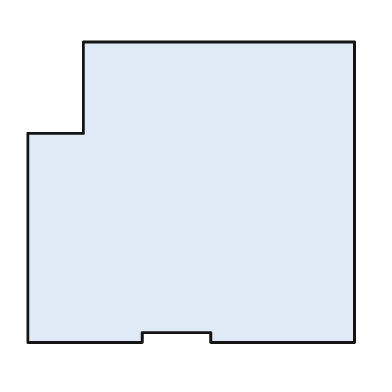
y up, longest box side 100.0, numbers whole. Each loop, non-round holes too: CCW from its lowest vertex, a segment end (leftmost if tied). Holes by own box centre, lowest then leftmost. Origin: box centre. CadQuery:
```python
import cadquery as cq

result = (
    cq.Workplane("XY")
    .moveTo(-50.0, -46.0)
    .lineTo(-15.0, -46.0)
    .lineTo(-15.0, -43.0)
    .lineTo(6.0, -43.0)
    .lineTo(6.0, -46.0)
    .lineTo(50.0, -46.0)
    .lineTo(50.0, 46.0)
    .lineTo(-33.0, 46.0)
    .lineTo(-33.0, 18.0)
    .lineTo(-50.0, 18.0)
    .close()
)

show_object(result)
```